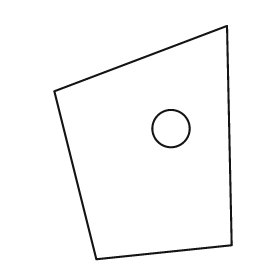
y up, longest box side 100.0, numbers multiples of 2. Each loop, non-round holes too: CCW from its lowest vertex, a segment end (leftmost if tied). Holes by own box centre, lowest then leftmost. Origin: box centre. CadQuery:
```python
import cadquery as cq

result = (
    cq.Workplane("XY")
    .moveTo(-20.0, -50.0)
    .lineTo(38.0, -44.0)
    .lineTo(36.0, 50.0)
    .lineTo(-38.0, 22.0)
    .close()
    .moveTo(12.0, 6.0)
    .circle(8.0)
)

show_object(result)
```